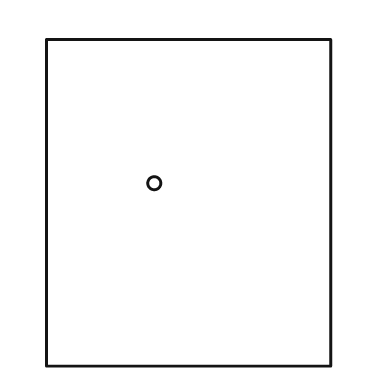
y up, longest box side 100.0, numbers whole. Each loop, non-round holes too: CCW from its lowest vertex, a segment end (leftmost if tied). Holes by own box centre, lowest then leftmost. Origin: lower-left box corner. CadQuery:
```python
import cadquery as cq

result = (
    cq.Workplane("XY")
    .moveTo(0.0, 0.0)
    .lineTo(87.0, 0.0)
    .lineTo(87.0, 100.0)
    .lineTo(0.0, 100.0)
    .close()
    .moveTo(33.0, 56.0)
    .circle(2.0)
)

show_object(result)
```